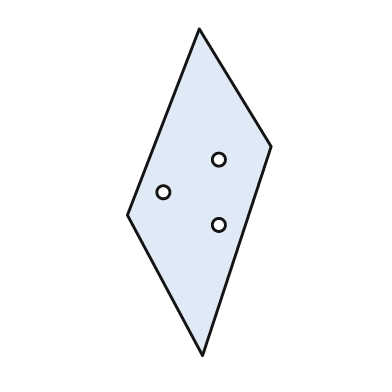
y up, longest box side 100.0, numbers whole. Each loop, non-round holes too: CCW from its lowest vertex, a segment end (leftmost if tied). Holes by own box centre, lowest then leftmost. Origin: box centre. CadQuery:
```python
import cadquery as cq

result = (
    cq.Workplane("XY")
    .moveTo(1.0, -50.0)
    .lineTo(22.0, 14.0)
    .lineTo(0.0, 50.0)
    .lineTo(-22.0, -7.0)
    .close()
    .moveTo(6.0, -10.0)
    .circle(2.0)
    .moveTo(-11.0, 0.0)
    .circle(2.0)
    .moveTo(6.0, 10.0)
    .circle(2.0)
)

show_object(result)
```